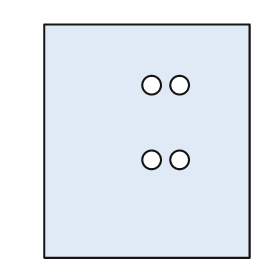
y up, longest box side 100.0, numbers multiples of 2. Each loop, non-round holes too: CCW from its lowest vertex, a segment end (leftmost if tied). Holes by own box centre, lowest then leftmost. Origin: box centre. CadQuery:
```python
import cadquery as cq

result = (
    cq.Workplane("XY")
    .moveTo(-44.0, -50.0)
    .lineTo(44.0, -50.0)
    .lineTo(44.0, 50.0)
    .lineTo(-44.0, 50.0)
    .close()
    .moveTo(2.0, -8.0)
    .circle(4.0)
    .moveTo(14.0, -8.0)
    .circle(4.0)
    .moveTo(2.0, 24.0)
    .circle(4.0)
    .moveTo(14.0, 24.0)
    .circle(4.0)
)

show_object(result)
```